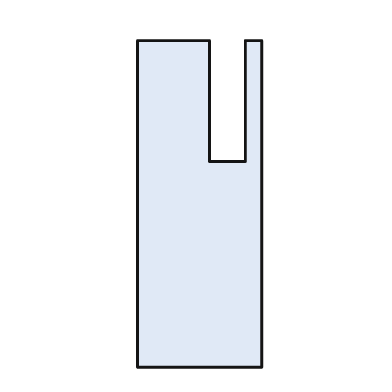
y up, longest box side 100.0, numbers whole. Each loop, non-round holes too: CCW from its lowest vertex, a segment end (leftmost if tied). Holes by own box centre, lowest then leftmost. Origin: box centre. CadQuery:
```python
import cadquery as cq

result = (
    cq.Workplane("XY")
    .moveTo(-19.0, -50.0)
    .lineTo(19.0, -50.0)
    .lineTo(19.0, 50.0)
    .lineTo(14.0, 50.0)
    .lineTo(14.0, 13.0)
    .lineTo(3.0, 13.0)
    .lineTo(3.0, 50.0)
    .lineTo(-19.0, 50.0)
    .close()
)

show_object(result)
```